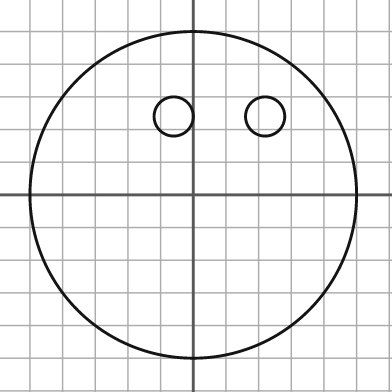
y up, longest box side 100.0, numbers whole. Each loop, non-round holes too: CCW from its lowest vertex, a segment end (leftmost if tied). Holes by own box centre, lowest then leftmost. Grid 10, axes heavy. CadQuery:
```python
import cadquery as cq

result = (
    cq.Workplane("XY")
    .moveTo(0.0, 0.0)
    .circle(50.0)
    .moveTo(-6.0, 24.0)
    .circle(6.0)
    .moveTo(22.0, 24.0)
    .circle(6.0)
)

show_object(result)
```